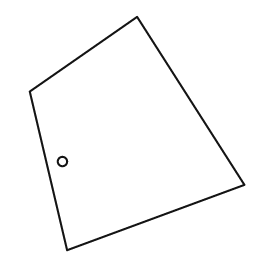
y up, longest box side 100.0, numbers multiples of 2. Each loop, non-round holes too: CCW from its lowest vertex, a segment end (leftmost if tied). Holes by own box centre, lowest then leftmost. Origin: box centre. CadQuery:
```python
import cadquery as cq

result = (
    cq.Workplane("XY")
    .moveTo(-30.0, -50.0)
    .lineTo(46.0, -22.0)
    .lineTo(0.0, 50.0)
    .lineTo(-46.0, 18.0)
    .close()
    .moveTo(-32.0, -12.0)
    .circle(2.0)
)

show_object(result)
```